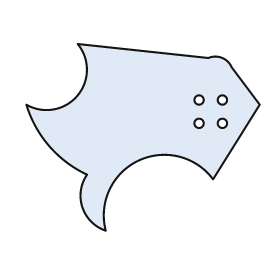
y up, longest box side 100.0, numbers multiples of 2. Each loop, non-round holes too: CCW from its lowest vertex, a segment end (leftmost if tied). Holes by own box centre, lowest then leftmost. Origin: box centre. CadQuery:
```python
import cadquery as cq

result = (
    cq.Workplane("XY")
    .moveTo(-16.0, -40.0)
    .threePointArc((-2.0, -10.0), (30.0, -18.0))
    .lineTo(50.0, 14.0)
    .lineTo(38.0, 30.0)
    .threePointArc((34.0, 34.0), (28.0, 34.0))
    .lineTo(-28.0, 40.0)
    .threePointArc((-28.0, 18.0), (-50.0, 14.0))
    .threePointArc((-40.0, -4.0), (-24.0, -16.0))
    .threePointArc((-26.0, -30.0), (-16.0, -40.0))
    .close()
    .moveTo(24.0, 6.0)
    .circle(2.0)
    .moveTo(34.0, 6.0)
    .circle(2.0)
    .moveTo(24.0, 16.0)
    .circle(2.0)
    .moveTo(34.0, 16.0)
    .circle(2.0)
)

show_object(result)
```